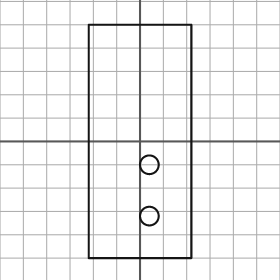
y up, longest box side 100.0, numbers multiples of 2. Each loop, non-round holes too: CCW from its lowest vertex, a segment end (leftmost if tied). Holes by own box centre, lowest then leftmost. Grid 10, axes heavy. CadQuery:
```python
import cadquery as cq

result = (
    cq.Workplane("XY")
    .moveTo(-22.0, -50.0)
    .lineTo(22.0, -50.0)
    .lineTo(22.0, 50.0)
    .lineTo(-22.0, 50.0)
    .close()
    .moveTo(4.0, -32.0)
    .circle(4.0)
    .moveTo(4.0, -10.0)
    .circle(4.0)
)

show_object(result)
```